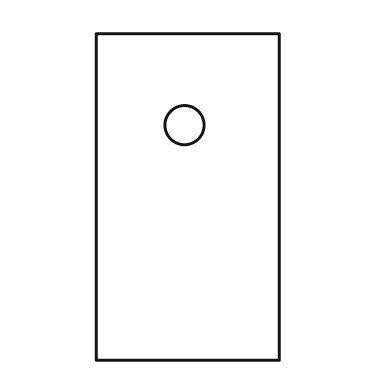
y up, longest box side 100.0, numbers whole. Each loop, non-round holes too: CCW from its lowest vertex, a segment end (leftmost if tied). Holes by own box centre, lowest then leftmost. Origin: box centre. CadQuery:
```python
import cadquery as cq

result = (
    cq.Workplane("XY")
    .moveTo(-28.0, -50.0)
    .lineTo(28.0, -50.0)
    .lineTo(28.0, 50.0)
    .lineTo(-28.0, 50.0)
    .close()
    .moveTo(-1.0, 22.0)
    .circle(6.0)
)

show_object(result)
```